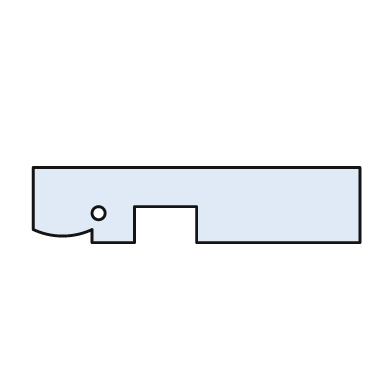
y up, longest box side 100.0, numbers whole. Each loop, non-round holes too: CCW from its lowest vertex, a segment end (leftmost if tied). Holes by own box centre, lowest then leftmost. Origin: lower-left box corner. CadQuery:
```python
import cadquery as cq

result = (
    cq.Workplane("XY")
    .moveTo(18.0, 0.0)
    .lineTo(31.0, 0.0)
    .lineTo(31.0, 11.0)
    .lineTo(50.0, 11.0)
    .lineTo(50.0, 0.0)
    .lineTo(100.0, 0.0)
    .lineTo(100.0, 23.0)
    .lineTo(0.0, 23.0)
    .lineTo(0.0, 4.0)
    .threePointArc((9.0, 2.0), (18.0, 4.0))
    .close()
    .moveTo(20.0, 9.0)
    .circle(2.0)
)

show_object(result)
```